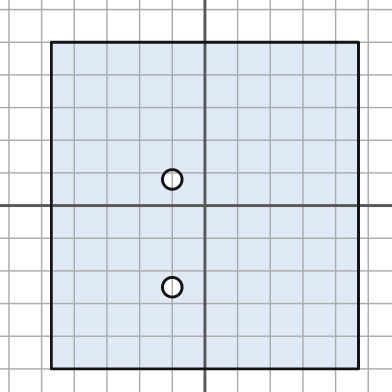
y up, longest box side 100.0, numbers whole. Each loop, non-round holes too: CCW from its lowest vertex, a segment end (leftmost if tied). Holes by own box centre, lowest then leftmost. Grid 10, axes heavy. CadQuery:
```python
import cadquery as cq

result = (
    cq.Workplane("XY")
    .moveTo(-47.0, -50.0)
    .lineTo(47.0, -50.0)
    .lineTo(47.0, 50.0)
    .lineTo(-47.0, 50.0)
    .close()
    .moveTo(-10.0, -25.0)
    .circle(3.0)
    .moveTo(-10.0, 8.0)
    .circle(3.0)
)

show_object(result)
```